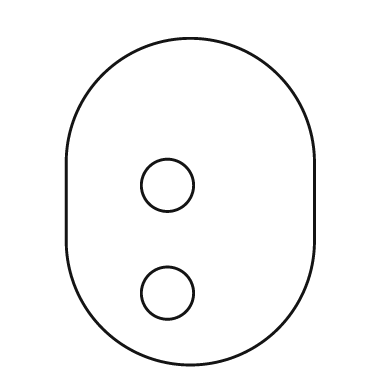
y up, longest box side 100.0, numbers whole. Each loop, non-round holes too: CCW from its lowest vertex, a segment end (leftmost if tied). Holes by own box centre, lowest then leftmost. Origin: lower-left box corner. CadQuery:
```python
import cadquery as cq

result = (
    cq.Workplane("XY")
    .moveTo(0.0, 38.0)
    .threePointArc((38.0, 0.0), (76.0, 38.0))
    .lineTo(76.0, 62.0)
    .threePointArc((38.0, 100.0), (0.0, 62.0))
    .close()
    .moveTo(31.0, 22.0)
    .circle(8.0)
    .moveTo(31.0, 55.0)
    .circle(8.0)
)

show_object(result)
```